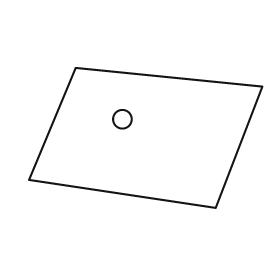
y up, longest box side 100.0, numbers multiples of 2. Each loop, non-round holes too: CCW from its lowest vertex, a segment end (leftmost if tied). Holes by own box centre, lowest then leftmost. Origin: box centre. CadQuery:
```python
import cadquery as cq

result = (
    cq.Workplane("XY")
    .moveTo(30.0, -30.0)
    .lineTo(50.0, 22.0)
    .lineTo(-30.0, 30.0)
    .lineTo(-50.0, -18.0)
    .close()
    .moveTo(-10.0, 8.0)
    .circle(4.0)
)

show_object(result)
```